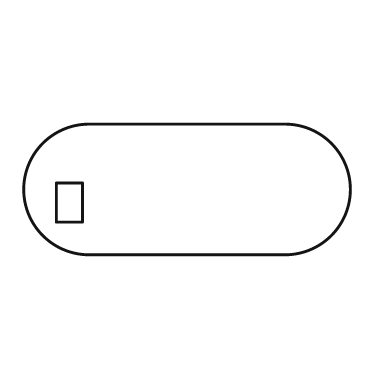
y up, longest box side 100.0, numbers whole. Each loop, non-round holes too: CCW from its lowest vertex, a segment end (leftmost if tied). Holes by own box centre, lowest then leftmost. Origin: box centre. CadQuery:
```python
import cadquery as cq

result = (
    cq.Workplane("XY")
    .moveTo(-30.0, -20.0)
    .lineTo(30.0, -20.0)
    .threePointArc((50.0, 0.0), (30.0, 20.0))
    .lineTo(-30.0, 20.0)
    .threePointArc((-50.0, 0.0), (-30.0, -20.0))
    .close()
    .moveTo(-40.0, -10.0)
    .lineTo(-32.0, -10.0)
    .lineTo(-32.0, 2.0)
    .lineTo(-40.0, 2.0)
    .close()
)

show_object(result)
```